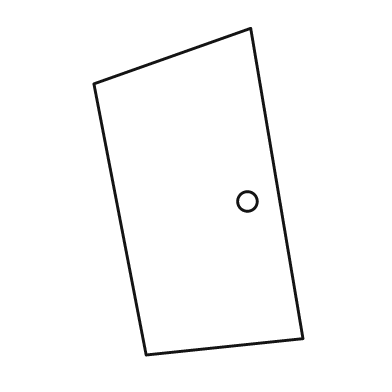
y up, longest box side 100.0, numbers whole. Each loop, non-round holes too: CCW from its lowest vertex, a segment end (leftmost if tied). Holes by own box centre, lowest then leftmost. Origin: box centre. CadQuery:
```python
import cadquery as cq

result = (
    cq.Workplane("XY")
    .moveTo(-16.0, -50.0)
    .lineTo(32.0, -45.0)
    .lineTo(16.0, 50.0)
    .lineTo(-32.0, 33.0)
    .close()
    .moveTo(15.0, -3.0)
    .circle(3.0)
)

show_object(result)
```